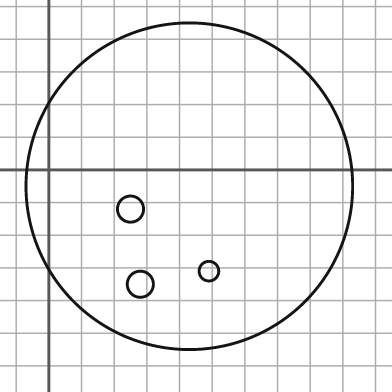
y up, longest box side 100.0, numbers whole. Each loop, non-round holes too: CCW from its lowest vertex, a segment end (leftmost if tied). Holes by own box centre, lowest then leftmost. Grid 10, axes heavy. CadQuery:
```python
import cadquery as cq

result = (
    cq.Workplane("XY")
    .moveTo(43.0, -5.0)
    .circle(50.0)
    .moveTo(28.0, -35.0)
    .circle(4.0)
    .moveTo(49.0, -31.0)
    .circle(3.0)
    .moveTo(25.0, -12.0)
    .circle(4.0)
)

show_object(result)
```